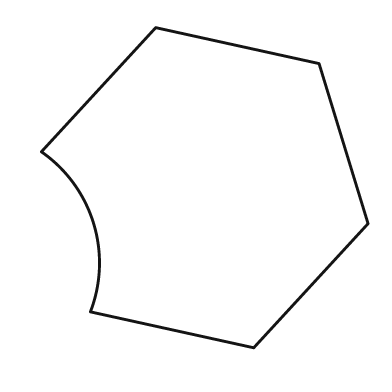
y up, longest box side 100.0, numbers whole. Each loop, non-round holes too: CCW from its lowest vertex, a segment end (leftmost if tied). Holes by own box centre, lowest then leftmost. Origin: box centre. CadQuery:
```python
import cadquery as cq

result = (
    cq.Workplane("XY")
    .moveTo(15.0, -49.0)
    .lineTo(50.0, -11.0)
    .lineTo(35.0, 38.0)
    .lineTo(-15.0, 49.0)
    .lineTo(-50.0, 11.0)
    .threePointArc((-34.0, -11.0), (-35.0, -38.0))
    .close()
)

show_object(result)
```